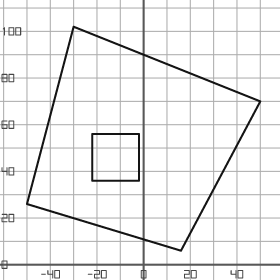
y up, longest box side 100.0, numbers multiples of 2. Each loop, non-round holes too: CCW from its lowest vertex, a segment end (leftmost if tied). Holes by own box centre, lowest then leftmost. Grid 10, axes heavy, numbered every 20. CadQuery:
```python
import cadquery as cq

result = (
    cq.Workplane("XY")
    .moveTo(16.0, 6.0)
    .lineTo(50.0, 70.0)
    .lineTo(-30.0, 102.0)
    .lineTo(-50.0, 26.0)
    .close()
    .moveTo(-22.0, 36.0)
    .lineTo(-2.0, 36.0)
    .lineTo(-2.0, 56.0)
    .lineTo(-22.0, 56.0)
    .close()
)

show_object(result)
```